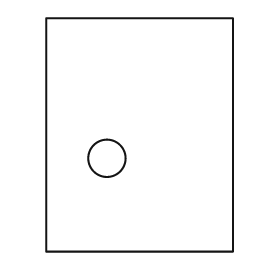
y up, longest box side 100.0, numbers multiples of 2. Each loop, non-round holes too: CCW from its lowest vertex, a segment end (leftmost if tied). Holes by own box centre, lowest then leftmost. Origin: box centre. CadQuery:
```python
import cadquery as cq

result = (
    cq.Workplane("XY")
    .moveTo(-40.0, -50.0)
    .lineTo(40.0, -50.0)
    .lineTo(40.0, 50.0)
    .lineTo(-40.0, 50.0)
    .close()
    .moveTo(-14.0, -10.0)
    .circle(8.0)
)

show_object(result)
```